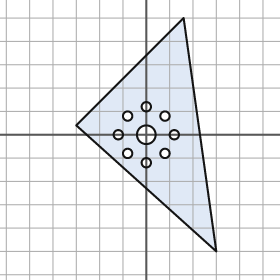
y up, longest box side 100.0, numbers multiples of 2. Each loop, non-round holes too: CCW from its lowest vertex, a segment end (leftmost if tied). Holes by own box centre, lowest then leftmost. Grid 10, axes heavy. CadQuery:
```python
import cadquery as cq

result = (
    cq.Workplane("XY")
    .moveTo(30.0, -50.0)
    .lineTo(16.0, 50.0)
    .lineTo(-30.0, 4.0)
    .close()
    .moveTo(0.0, -12.0)
    .circle(2.0)
    .moveTo(-8.0, -8.0)
    .circle(2.0)
    .moveTo(8.0, -8.0)
    .circle(2.0)
    .moveTo(-12.0, 0.0)
    .circle(2.0)
    .moveTo(0.0, 0.0)
    .circle(4.0)
    .moveTo(12.0, 0.0)
    .circle(2.0)
    .moveTo(-8.0, 8.0)
    .circle(2.0)
    .moveTo(8.0, 8.0)
    .circle(2.0)
    .moveTo(0.0, 12.0)
    .circle(2.0)
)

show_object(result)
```